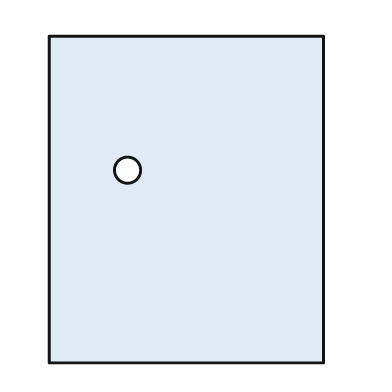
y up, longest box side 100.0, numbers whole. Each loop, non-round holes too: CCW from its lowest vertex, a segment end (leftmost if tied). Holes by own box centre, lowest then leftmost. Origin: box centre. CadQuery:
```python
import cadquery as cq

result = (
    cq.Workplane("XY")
    .moveTo(-42.0, -50.0)
    .lineTo(42.0, -50.0)
    .lineTo(42.0, 50.0)
    .lineTo(-42.0, 50.0)
    .close()
    .moveTo(-18.0, 9.0)
    .circle(4.0)
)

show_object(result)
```